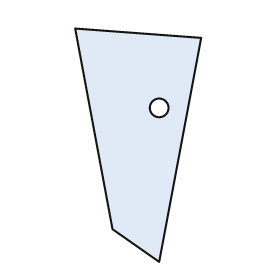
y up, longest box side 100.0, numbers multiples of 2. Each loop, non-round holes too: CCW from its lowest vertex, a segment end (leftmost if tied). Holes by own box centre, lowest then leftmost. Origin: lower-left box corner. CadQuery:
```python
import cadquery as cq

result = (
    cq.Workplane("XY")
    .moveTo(36.0, 0.0)
    .lineTo(54.0, 96.0)
    .lineTo(0.0, 100.0)
    .lineTo(16.0, 14.0)
    .close()
    .moveTo(36.0, 66.0)
    .circle(4.0)
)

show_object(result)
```